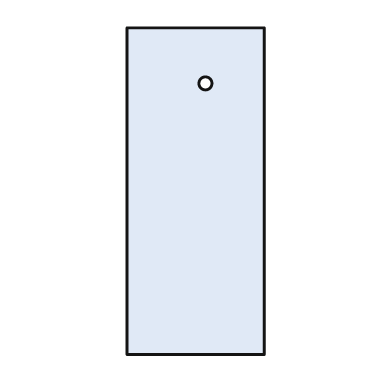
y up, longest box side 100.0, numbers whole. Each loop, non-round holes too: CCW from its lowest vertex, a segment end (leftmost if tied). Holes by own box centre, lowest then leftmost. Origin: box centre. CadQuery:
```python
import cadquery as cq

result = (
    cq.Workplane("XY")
    .moveTo(-21.0, -50.0)
    .lineTo(21.0, -50.0)
    .lineTo(21.0, 50.0)
    .lineTo(-21.0, 50.0)
    .close()
    .moveTo(3.0, 33.0)
    .circle(2.0)
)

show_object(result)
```